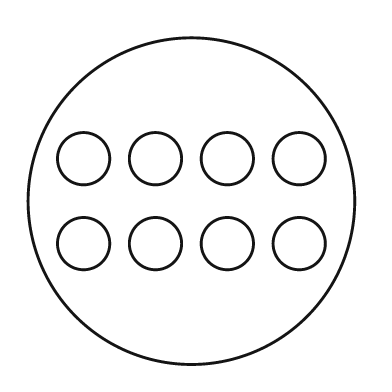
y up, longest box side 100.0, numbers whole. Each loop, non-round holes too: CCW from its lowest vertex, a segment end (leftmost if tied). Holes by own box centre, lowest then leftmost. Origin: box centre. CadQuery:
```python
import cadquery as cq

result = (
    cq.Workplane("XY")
    .moveTo(0.0, 0.0)
    .circle(50.0)
    .moveTo(-33.0, -13.0)
    .circle(8.0)
    .moveTo(-11.0, -13.0)
    .circle(8.0)
    .moveTo(11.0, -13.0)
    .circle(8.0)
    .moveTo(33.0, -13.0)
    .circle(8.0)
    .moveTo(-33.0, 13.0)
    .circle(8.0)
    .moveTo(-11.0, 13.0)
    .circle(8.0)
    .moveTo(11.0, 13.0)
    .circle(8.0)
    .moveTo(33.0, 13.0)
    .circle(8.0)
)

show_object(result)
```